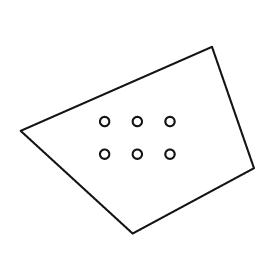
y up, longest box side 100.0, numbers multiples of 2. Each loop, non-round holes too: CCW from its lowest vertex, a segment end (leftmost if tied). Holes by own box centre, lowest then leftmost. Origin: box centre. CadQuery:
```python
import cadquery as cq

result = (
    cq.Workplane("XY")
    .moveTo(-2.0, -40.0)
    .lineTo(50.0, -12.0)
    .lineTo(32.0, 40.0)
    .lineTo(-50.0, 4.0)
    .close()
    .moveTo(-14.0, -6.0)
    .circle(2.0)
    .moveTo(0.0, -6.0)
    .circle(2.0)
    .moveTo(14.0, -6.0)
    .circle(2.0)
    .moveTo(-14.0, 8.0)
    .circle(2.0)
    .moveTo(0.0, 8.0)
    .circle(2.0)
    .moveTo(14.0, 8.0)
    .circle(2.0)
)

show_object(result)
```